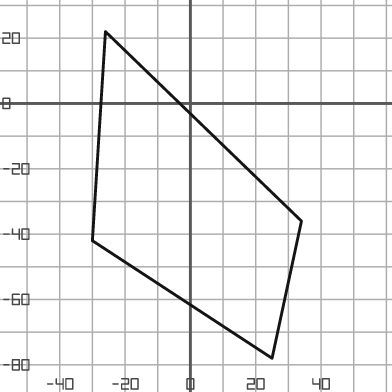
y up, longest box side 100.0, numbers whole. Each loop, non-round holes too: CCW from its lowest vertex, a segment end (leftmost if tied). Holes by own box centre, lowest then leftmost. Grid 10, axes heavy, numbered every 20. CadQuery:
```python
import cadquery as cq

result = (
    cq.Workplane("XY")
    .moveTo(25.0, -78.0)
    .lineTo(34.0, -36.0)
    .lineTo(-26.0, 22.0)
    .lineTo(-30.0, -42.0)
    .close()
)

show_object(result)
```